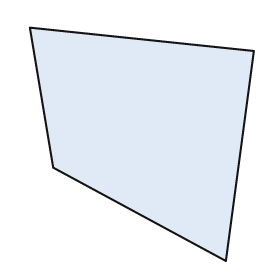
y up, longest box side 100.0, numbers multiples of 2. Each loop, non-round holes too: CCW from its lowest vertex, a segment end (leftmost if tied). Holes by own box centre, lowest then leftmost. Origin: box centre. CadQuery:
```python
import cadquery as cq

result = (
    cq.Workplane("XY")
    .moveTo(36.0, -50.0)
    .lineTo(48.0, 40.0)
    .lineTo(-48.0, 50.0)
    .lineTo(-38.0, -10.0)
    .close()
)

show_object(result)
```